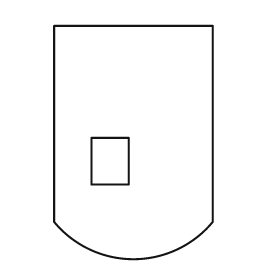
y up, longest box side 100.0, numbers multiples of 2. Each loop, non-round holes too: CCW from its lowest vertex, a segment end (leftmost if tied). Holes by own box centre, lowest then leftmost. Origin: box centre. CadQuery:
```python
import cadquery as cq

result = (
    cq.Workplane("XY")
    .moveTo(-34.0, -34.0)
    .threePointArc((0.0, -50.0), (34.0, -34.0))
    .lineTo(34.0, 50.0)
    .lineTo(-34.0, 50.0)
    .close()
    .moveTo(-18.0, -18.0)
    .lineTo(-2.0, -18.0)
    .lineTo(-2.0, 2.0)
    .lineTo(-18.0, 2.0)
    .close()
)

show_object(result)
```